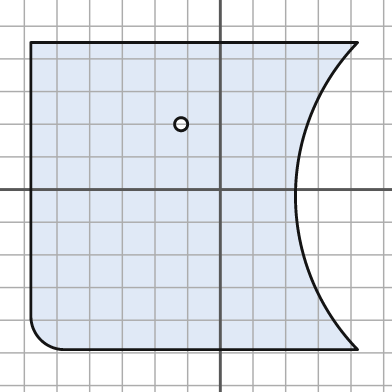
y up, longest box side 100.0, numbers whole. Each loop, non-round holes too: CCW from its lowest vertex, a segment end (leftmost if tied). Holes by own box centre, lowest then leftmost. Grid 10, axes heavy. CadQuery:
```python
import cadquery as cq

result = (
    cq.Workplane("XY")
    .moveTo(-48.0, -49.0)
    .lineTo(42.0, -49.0)
    .threePointArc((23.0, -2.0), (42.0, 45.0))
    .lineTo(-58.0, 45.0)
    .lineTo(-58.0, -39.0)
    .threePointArc((-55.0, -46.0), (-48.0, -49.0))
    .close()
    .moveTo(-12.0, 20.0)
    .circle(2.0)
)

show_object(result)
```